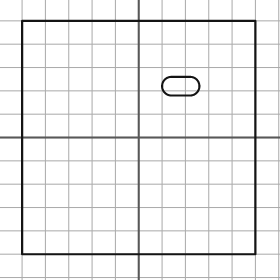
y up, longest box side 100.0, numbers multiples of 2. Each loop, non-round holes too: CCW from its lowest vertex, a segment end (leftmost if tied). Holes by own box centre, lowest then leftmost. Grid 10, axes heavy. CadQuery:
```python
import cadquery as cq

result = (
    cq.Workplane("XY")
    .moveTo(-50.0, -50.0)
    .lineTo(50.0, -50.0)
    .lineTo(50.0, 50.0)
    .lineTo(-50.0, 50.0)
    .close()
    .moveTo(14.0, 18.0)
    .lineTo(22.0, 18.0)
    .threePointArc((26.0, 22.0), (22.0, 26.0))
    .lineTo(14.0, 26.0)
    .threePointArc((10.0, 22.0), (14.0, 18.0))
    .close()
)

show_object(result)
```